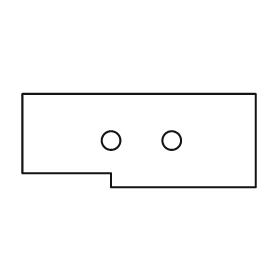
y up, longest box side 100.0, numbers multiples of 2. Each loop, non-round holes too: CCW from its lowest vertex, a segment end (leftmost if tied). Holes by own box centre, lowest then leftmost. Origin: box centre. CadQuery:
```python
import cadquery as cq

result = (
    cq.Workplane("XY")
    .moveTo(-12.0, -20.0)
    .lineTo(50.0, -20.0)
    .lineTo(50.0, 20.0)
    .lineTo(-50.0, 20.0)
    .lineTo(-50.0, -14.0)
    .lineTo(-12.0, -14.0)
    .close()
    .moveTo(-12.0, 0.0)
    .circle(4.0)
    .moveTo(14.0, 0.0)
    .circle(4.0)
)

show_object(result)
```